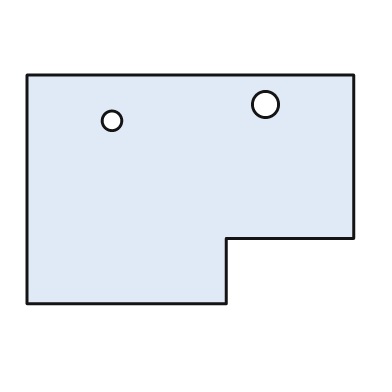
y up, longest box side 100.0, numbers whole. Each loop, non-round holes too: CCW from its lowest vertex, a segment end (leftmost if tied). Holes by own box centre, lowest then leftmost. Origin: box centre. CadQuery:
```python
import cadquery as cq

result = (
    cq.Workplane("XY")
    .moveTo(-50.0, -35.0)
    .lineTo(11.0, -35.0)
    .lineTo(11.0, -15.0)
    .lineTo(50.0, -15.0)
    .lineTo(50.0, 35.0)
    .lineTo(-50.0, 35.0)
    .close()
    .moveTo(-24.0, 21.0)
    .circle(3.0)
    .moveTo(23.0, 26.0)
    .circle(4.0)
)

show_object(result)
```